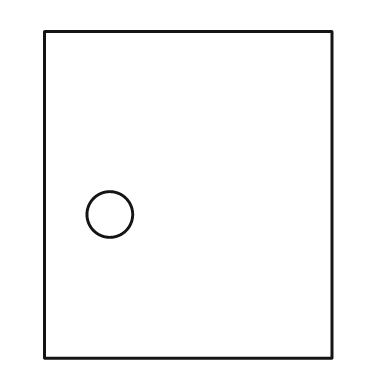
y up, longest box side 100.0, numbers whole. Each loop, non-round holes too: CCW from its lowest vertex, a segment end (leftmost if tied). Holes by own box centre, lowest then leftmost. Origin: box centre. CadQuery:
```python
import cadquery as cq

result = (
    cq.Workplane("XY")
    .moveTo(-44.0, -50.0)
    .lineTo(44.0, -50.0)
    .lineTo(44.0, 50.0)
    .lineTo(-44.0, 50.0)
    .close()
    .moveTo(-24.0, -6.0)
    .circle(7.0)
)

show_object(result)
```